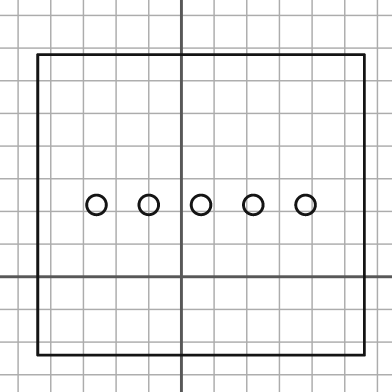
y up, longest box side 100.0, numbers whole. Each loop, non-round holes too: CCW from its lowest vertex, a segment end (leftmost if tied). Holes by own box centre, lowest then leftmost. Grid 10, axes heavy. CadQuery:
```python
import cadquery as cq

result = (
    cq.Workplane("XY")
    .moveTo(-44.0, -24.0)
    .lineTo(56.0, -24.0)
    .lineTo(56.0, 68.0)
    .lineTo(-44.0, 68.0)
    .close()
    .moveTo(-26.0, 22.0)
    .circle(3.0)
    .moveTo(-10.0, 22.0)
    .circle(3.0)
    .moveTo(6.0, 22.0)
    .circle(3.0)
    .moveTo(22.0, 22.0)
    .circle(3.0)
    .moveTo(38.0, 22.0)
    .circle(3.0)
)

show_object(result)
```